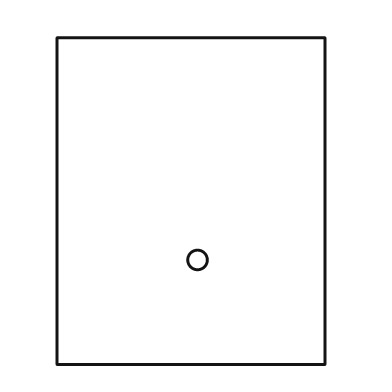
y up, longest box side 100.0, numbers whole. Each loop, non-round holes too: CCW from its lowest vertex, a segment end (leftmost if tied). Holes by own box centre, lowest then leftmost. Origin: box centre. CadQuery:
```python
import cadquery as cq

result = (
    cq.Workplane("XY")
    .moveTo(-41.0, -50.0)
    .lineTo(41.0, -50.0)
    .lineTo(41.0, 50.0)
    .lineTo(-41.0, 50.0)
    .close()
    .moveTo(2.0, -18.0)
    .circle(3.0)
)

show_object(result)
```